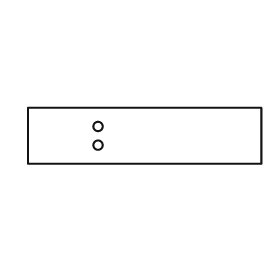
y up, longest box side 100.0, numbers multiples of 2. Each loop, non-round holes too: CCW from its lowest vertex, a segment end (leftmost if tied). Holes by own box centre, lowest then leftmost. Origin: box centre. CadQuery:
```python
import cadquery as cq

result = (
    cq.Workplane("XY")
    .moveTo(-50.0, -12.0)
    .lineTo(50.0, -12.0)
    .lineTo(50.0, 12.0)
    .lineTo(-50.0, 12.0)
    .close()
    .moveTo(-20.0, -4.0)
    .circle(2.0)
    .moveTo(-20.0, 4.0)
    .circle(2.0)
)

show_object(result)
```